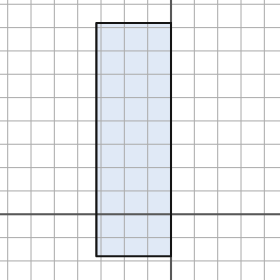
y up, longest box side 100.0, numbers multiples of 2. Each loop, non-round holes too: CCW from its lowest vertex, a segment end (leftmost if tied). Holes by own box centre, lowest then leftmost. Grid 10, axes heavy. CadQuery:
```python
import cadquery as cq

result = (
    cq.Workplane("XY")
    .moveTo(-32.0, -18.0)
    .lineTo(0.0, -18.0)
    .lineTo(0.0, 82.0)
    .lineTo(-32.0, 82.0)
    .close()
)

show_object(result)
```